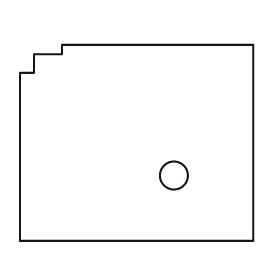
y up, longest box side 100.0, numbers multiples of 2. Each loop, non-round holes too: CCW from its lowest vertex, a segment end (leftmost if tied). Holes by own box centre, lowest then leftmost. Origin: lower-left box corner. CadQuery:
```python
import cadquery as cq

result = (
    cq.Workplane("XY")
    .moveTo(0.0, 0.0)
    .lineTo(100.0, 0.0)
    .lineTo(100.0, 84.0)
    .lineTo(18.0, 84.0)
    .lineTo(18.0, 80.0)
    .lineTo(6.0, 80.0)
    .lineTo(6.0, 72.0)
    .lineTo(0.0, 72.0)
    .close()
    .moveTo(66.0, 28.0)
    .circle(6.0)
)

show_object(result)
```